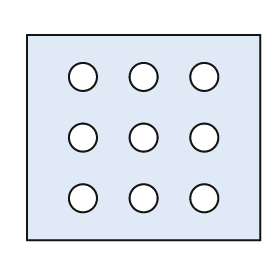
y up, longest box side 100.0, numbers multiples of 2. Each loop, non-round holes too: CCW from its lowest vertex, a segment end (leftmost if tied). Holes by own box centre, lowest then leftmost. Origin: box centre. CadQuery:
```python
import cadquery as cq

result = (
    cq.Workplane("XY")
    .moveTo(-50.0, -44.0)
    .lineTo(50.0, -44.0)
    .lineTo(50.0, 44.0)
    .lineTo(-50.0, 44.0)
    .close()
    .moveTo(-26.0, -26.0)
    .circle(6.0)
    .moveTo(0.0, -26.0)
    .circle(6.0)
    .moveTo(26.0, -26.0)
    .circle(6.0)
    .moveTo(-26.0, 0.0)
    .circle(6.0)
    .moveTo(0.0, 0.0)
    .circle(6.0)
    .moveTo(26.0, 0.0)
    .circle(6.0)
    .moveTo(-26.0, 26.0)
    .circle(6.0)
    .moveTo(0.0, 26.0)
    .circle(6.0)
    .moveTo(26.0, 26.0)
    .circle(6.0)
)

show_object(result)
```